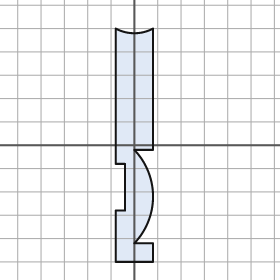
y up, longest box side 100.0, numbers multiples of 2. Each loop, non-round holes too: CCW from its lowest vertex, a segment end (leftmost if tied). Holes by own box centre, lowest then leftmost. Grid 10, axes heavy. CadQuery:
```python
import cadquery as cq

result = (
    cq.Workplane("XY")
    .moveTo(-8.0, -50.0)
    .lineTo(8.0, -50.0)
    .lineTo(8.0, -42.0)
    .lineTo(0.0, -42.0)
    .threePointArc((8.0, -22.0), (0.0, -2.0))
    .lineTo(8.0, -2.0)
    .lineTo(8.0, 50.0)
    .threePointArc((0.0, 48.0), (-8.0, 50.0))
    .lineTo(-8.0, -8.0)
    .lineTo(-4.0, -8.0)
    .lineTo(-4.0, -28.0)
    .lineTo(-8.0, -28.0)
    .close()
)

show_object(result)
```